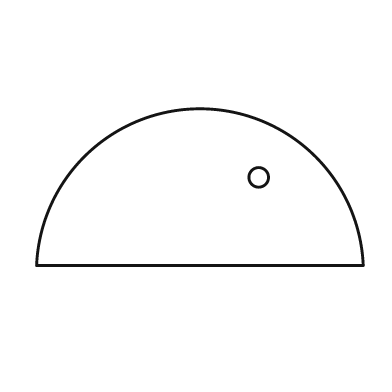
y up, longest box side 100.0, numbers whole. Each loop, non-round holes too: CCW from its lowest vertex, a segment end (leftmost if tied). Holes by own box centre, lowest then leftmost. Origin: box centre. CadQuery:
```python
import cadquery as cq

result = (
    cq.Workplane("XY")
    .moveTo(-50.0, -24.0)
    .lineTo(50.0, -24.0)
    .threePointArc((0.0, 24.0), (-50.0, -24.0))
    .close()
    .moveTo(18.0, 3.0)
    .circle(3.0)
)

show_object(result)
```